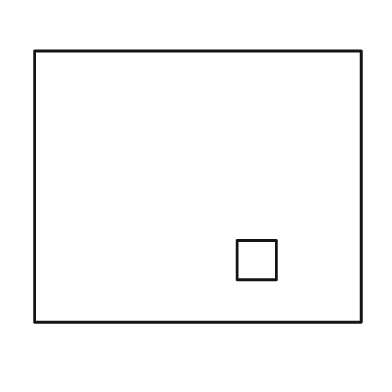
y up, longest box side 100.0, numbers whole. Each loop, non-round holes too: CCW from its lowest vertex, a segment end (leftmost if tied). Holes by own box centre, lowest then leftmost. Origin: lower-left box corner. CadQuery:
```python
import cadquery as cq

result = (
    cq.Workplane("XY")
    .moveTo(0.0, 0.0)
    .lineTo(100.0, 0.0)
    .lineTo(100.0, 83.0)
    .lineTo(0.0, 83.0)
    .close()
    .moveTo(62.0, 13.0)
    .lineTo(74.0, 13.0)
    .lineTo(74.0, 25.0)
    .lineTo(62.0, 25.0)
    .close()
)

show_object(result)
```